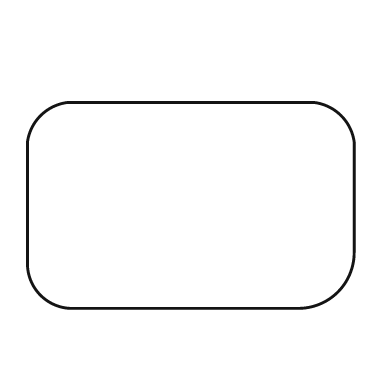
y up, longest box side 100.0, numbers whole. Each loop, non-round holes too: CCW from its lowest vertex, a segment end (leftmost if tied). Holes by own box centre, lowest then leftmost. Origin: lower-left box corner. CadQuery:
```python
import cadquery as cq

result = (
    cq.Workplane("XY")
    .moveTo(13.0, 0.0)
    .lineTo(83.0, 0.0)
    .threePointArc((95.0, 5.0), (100.0, 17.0))
    .lineTo(100.0, 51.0)
    .threePointArc((96.0, 59.0), (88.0, 63.0))
    .lineTo(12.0, 63.0)
    .threePointArc((4.0, 59.0), (0.0, 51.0))
    .lineTo(0.0, 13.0)
    .threePointArc((4.0, 4.0), (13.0, 0.0))
    .close()
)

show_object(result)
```